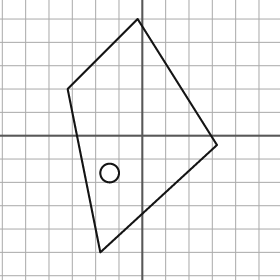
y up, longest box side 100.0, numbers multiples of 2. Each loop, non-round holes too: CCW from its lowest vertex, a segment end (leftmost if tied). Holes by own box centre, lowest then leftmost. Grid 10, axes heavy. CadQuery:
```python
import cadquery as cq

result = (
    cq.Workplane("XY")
    .moveTo(-18.0, -50.0)
    .lineTo(32.0, -4.0)
    .lineTo(-2.0, 50.0)
    .lineTo(-32.0, 20.0)
    .close()
    .moveTo(-14.0, -16.0)
    .circle(4.0)
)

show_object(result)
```